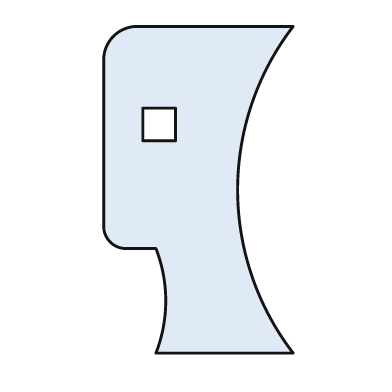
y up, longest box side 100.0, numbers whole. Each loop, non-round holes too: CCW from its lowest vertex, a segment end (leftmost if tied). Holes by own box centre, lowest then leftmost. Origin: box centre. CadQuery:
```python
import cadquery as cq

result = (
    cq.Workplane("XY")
    .moveTo(-13.0, -50.0)
    .lineTo(29.0, -50.0)
    .threePointArc((12.0, 0.0), (29.0, 50.0))
    .lineTo(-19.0, 50.0)
    .threePointArc((-26.0, 47.0), (-29.0, 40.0))
    .lineTo(-29.0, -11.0)
    .threePointArc((-27.0, -16.0), (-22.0, -18.0))
    .lineTo(-13.0, -18.0)
    .threePointArc((-10.0, -34.0), (-13.0, -50.0))
    .close()
    .moveTo(-17.0, 15.0)
    .lineTo(-7.0, 15.0)
    .lineTo(-7.0, 25.0)
    .lineTo(-17.0, 25.0)
    .close()
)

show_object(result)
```